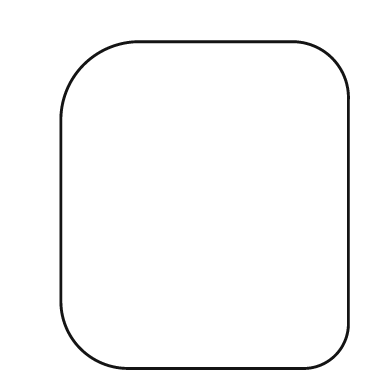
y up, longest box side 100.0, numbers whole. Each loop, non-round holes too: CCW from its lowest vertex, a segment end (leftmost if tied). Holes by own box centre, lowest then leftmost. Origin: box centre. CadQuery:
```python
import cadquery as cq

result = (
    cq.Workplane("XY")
    .moveTo(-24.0, -50.0)
    .lineTo(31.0, -50.0)
    .threePointArc((40.0, -46.0), (44.0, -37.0))
    .lineTo(44.0, 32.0)
    .threePointArc((39.0, 45.0), (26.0, 50.0))
    .lineTo(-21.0, 50.0)
    .threePointArc((-37.0, 43.0), (-44.0, 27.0))
    .lineTo(-44.0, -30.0)
    .threePointArc((-38.0, -44.0), (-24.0, -50.0))
    .close()
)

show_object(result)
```